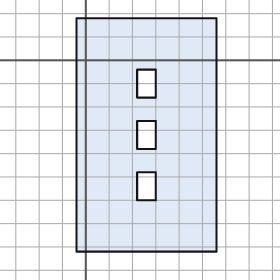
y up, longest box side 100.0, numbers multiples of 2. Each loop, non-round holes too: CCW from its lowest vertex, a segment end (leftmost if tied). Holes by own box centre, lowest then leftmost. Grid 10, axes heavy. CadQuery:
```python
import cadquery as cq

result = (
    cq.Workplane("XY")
    .moveTo(-4.0, -82.0)
    .lineTo(56.0, -82.0)
    .lineTo(56.0, 18.0)
    .lineTo(-4.0, 18.0)
    .close()
    .moveTo(22.0, -60.0)
    .lineTo(30.0, -60.0)
    .lineTo(30.0, -48.0)
    .lineTo(22.0, -48.0)
    .close()
    .moveTo(22.0, -38.0)
    .lineTo(30.0, -38.0)
    .lineTo(30.0, -26.0)
    .lineTo(22.0, -26.0)
    .close()
    .moveTo(22.0, -16.0)
    .lineTo(30.0, -16.0)
    .lineTo(30.0, -4.0)
    .lineTo(22.0, -4.0)
    .close()
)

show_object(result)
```